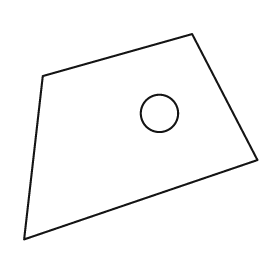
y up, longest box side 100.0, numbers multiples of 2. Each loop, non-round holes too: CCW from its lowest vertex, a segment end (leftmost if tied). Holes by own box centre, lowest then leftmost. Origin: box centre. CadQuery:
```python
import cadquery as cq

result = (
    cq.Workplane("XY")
    .moveTo(-50.0, -44.0)
    .lineTo(50.0, -10.0)
    .lineTo(22.0, 44.0)
    .lineTo(-42.0, 26.0)
    .close()
    .moveTo(8.0, 10.0)
    .circle(8.0)
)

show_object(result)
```